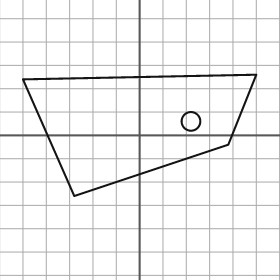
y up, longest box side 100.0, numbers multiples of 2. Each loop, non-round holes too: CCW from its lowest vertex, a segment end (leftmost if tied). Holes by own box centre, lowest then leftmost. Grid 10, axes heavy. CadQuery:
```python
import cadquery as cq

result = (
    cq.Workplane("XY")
    .moveTo(-28.0, -26.0)
    .lineTo(38.0, -4.0)
    .lineTo(50.0, 26.0)
    .lineTo(-50.0, 24.0)
    .close()
    .moveTo(22.0, 6.0)
    .circle(4.0)
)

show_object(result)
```